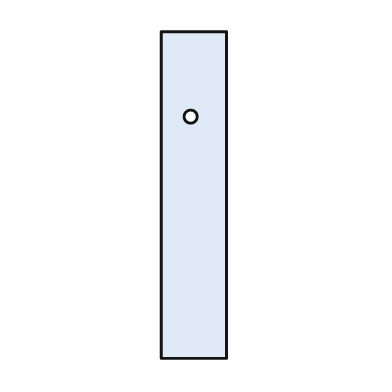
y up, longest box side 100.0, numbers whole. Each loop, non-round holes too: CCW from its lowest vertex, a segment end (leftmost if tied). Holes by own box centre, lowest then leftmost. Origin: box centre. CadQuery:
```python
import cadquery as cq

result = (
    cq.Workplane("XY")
    .moveTo(-10.0, -50.0)
    .lineTo(10.0, -50.0)
    .lineTo(10.0, 50.0)
    .lineTo(-10.0, 50.0)
    .close()
    .moveTo(-1.0, 24.0)
    .circle(2.0)
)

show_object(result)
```